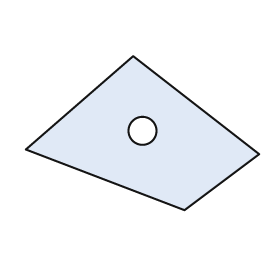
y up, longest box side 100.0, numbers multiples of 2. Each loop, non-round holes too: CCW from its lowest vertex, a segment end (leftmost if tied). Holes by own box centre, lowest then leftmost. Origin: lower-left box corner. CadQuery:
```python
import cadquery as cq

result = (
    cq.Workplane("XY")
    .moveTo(68.0, 0.0)
    .lineTo(100.0, 24.0)
    .lineTo(46.0, 66.0)
    .lineTo(0.0, 26.0)
    .close()
    .moveTo(50.0, 34.0)
    .circle(6.0)
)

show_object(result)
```